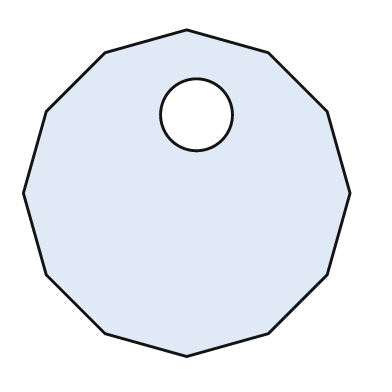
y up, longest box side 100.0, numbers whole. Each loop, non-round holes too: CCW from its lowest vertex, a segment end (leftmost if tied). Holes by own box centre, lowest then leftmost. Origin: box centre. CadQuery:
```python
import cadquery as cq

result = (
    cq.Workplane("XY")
    .moveTo(0.0, -50.0)
    .lineTo(25.0, -43.0)
    .lineTo(43.0, -25.0)
    .lineTo(50.0, 0.0)
    .lineTo(43.0, 25.0)
    .lineTo(25.0, 43.0)
    .lineTo(0.0, 50.0)
    .lineTo(-25.0, 43.0)
    .lineTo(-43.0, 25.0)
    .lineTo(-50.0, 0.0)
    .lineTo(-43.0, -25.0)
    .lineTo(-25.0, -43.0)
    .close()
    .moveTo(3.0, 24.0)
    .circle(11.0)
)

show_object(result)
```